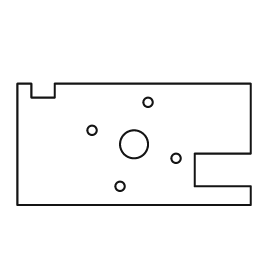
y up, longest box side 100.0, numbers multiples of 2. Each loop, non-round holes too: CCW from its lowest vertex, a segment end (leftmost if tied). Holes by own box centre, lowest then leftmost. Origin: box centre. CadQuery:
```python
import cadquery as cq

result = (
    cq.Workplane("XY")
    .moveTo(-50.0, -26.0)
    .lineTo(50.0, -26.0)
    .lineTo(50.0, -18.0)
    .lineTo(26.0, -18.0)
    .lineTo(26.0, -4.0)
    .lineTo(50.0, -4.0)
    .lineTo(50.0, 26.0)
    .lineTo(-34.0, 26.0)
    .lineTo(-34.0, 20.0)
    .lineTo(-44.0, 20.0)
    .lineTo(-44.0, 26.0)
    .lineTo(-50.0, 26.0)
    .close()
    .moveTo(-6.0, -18.0)
    .circle(2.0)
    .moveTo(18.0, -6.0)
    .circle(2.0)
    .moveTo(0.0, 0.0)
    .circle(6.0)
    .moveTo(-18.0, 6.0)
    .circle(2.0)
    .moveTo(6.0, 18.0)
    .circle(2.0)
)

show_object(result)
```